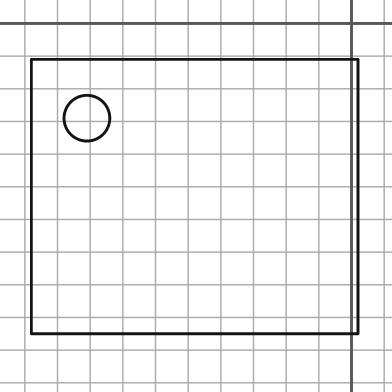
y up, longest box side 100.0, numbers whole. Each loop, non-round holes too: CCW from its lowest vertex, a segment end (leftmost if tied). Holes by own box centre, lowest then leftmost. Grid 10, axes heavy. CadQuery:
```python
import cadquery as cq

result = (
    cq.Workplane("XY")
    .moveTo(-98.0, -95.0)
    .lineTo(2.0, -95.0)
    .lineTo(2.0, -11.0)
    .lineTo(-98.0, -11.0)
    .close()
    .moveTo(-81.0, -29.0)
    .circle(7.0)
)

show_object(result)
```